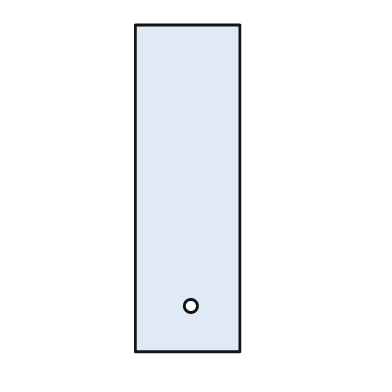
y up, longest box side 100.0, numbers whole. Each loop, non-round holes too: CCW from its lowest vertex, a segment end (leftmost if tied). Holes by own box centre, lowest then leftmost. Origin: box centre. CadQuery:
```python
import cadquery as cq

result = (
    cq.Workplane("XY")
    .moveTo(-16.0, -50.0)
    .lineTo(16.0, -50.0)
    .lineTo(16.0, 50.0)
    .lineTo(-16.0, 50.0)
    .close()
    .moveTo(1.0, -36.0)
    .circle(2.0)
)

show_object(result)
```